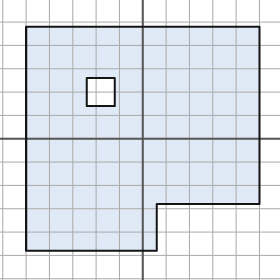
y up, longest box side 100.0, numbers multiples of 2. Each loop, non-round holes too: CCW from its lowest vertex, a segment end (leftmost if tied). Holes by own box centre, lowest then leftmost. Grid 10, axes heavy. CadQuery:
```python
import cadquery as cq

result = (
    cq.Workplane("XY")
    .moveTo(-50.0, -48.0)
    .lineTo(6.0, -48.0)
    .lineTo(6.0, -28.0)
    .lineTo(50.0, -28.0)
    .lineTo(50.0, 48.0)
    .lineTo(-50.0, 48.0)
    .close()
    .moveTo(-24.0, 14.0)
    .lineTo(-12.0, 14.0)
    .lineTo(-12.0, 26.0)
    .lineTo(-24.0, 26.0)
    .close()
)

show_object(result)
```